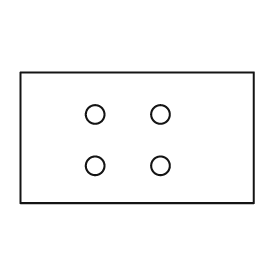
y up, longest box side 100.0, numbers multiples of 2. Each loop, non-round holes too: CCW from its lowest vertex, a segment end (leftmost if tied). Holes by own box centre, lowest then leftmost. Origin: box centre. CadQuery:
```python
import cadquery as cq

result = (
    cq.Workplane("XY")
    .moveTo(-50.0, -28.0)
    .lineTo(50.0, -28.0)
    .lineTo(50.0, 28.0)
    .lineTo(-50.0, 28.0)
    .close()
    .moveTo(-18.0, -12.0)
    .circle(4.0)
    .moveTo(10.0, -12.0)
    .circle(4.0)
    .moveTo(-18.0, 10.0)
    .circle(4.0)
    .moveTo(10.0, 10.0)
    .circle(4.0)
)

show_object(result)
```